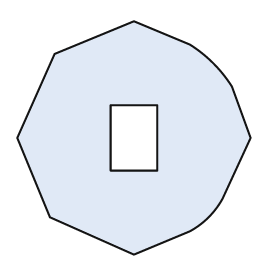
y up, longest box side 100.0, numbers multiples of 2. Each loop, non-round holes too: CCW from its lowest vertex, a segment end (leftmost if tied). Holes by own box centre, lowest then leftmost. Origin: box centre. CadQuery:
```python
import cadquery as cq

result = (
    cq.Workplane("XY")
    .moveTo(0.0, -50.0)
    .lineTo(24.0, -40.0)
    .threePointArc((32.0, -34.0), (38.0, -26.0))
    .lineTo(50.0, 0.0)
    .lineTo(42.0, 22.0)
    .threePointArc((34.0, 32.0), (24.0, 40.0))
    .lineTo(0.0, 50.0)
    .lineTo(-34.0, 36.0)
    .lineTo(-50.0, 0.0)
    .lineTo(-36.0, -34.0)
    .close()
    .moveTo(-10.0, -14.0)
    .lineTo(10.0, -14.0)
    .lineTo(10.0, 14.0)
    .lineTo(-10.0, 14.0)
    .close()
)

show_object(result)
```